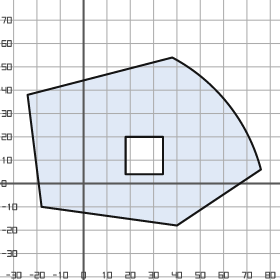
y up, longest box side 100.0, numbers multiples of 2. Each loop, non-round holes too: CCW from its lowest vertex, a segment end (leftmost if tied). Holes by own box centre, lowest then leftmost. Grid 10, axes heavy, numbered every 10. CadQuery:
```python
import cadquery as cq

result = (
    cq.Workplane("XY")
    .moveTo(40.0, -18.0)
    .lineTo(76.0, 6.0)
    .threePointArc((62.0, 34.0), (38.0, 54.0))
    .lineTo(-24.0, 38.0)
    .lineTo(-18.0, -10.0)
    .close()
    .moveTo(18.0, 4.0)
    .lineTo(34.0, 4.0)
    .lineTo(34.0, 20.0)
    .lineTo(18.0, 20.0)
    .close()
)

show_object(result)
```